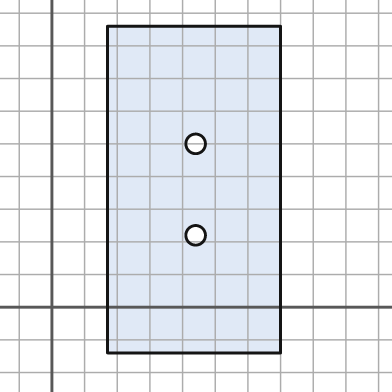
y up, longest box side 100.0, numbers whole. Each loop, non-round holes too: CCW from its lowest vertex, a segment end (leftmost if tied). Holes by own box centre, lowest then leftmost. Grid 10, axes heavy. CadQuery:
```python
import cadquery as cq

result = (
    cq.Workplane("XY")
    .moveTo(17.0, -14.0)
    .lineTo(70.0, -14.0)
    .lineTo(70.0, 86.0)
    .lineTo(17.0, 86.0)
    .close()
    .moveTo(44.0, 22.0)
    .circle(3.0)
    .moveTo(44.0, 50.0)
    .circle(3.0)
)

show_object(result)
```